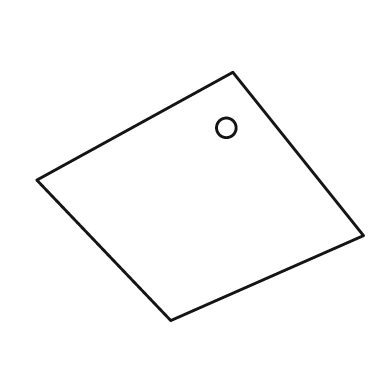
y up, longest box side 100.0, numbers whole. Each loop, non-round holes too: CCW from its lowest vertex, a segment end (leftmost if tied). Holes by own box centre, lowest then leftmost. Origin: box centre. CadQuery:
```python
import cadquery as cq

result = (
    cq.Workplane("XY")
    .moveTo(-9.0, -38.0)
    .lineTo(50.0, -12.0)
    .lineTo(10.0, 38.0)
    .lineTo(-50.0, 5.0)
    .close()
    .moveTo(8.0, 21.0)
    .circle(3.0)
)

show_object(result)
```